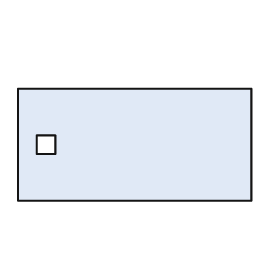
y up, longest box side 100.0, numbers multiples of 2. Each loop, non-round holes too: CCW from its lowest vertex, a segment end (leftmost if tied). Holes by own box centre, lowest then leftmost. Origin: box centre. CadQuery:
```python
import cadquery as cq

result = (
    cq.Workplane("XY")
    .moveTo(-50.0, -24.0)
    .lineTo(50.0, -24.0)
    .lineTo(50.0, 24.0)
    .lineTo(-50.0, 24.0)
    .close()
    .moveTo(-42.0, -4.0)
    .lineTo(-34.0, -4.0)
    .lineTo(-34.0, 4.0)
    .lineTo(-42.0, 4.0)
    .close()
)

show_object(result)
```